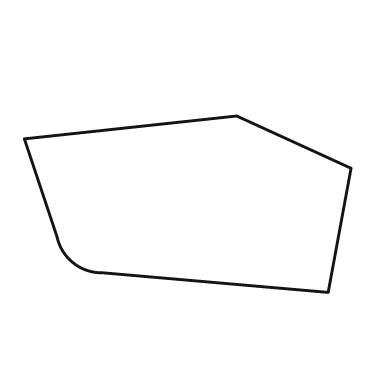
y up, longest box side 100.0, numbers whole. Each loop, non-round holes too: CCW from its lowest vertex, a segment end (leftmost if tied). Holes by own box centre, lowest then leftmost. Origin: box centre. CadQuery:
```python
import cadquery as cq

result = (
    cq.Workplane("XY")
    .moveTo(43.0, -27.0)
    .lineTo(50.0, 11.0)
    .lineTo(15.0, 27.0)
    .lineTo(-50.0, 20.0)
    .lineTo(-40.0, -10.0)
    .threePointArc((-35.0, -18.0), (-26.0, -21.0))
    .close()
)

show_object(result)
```